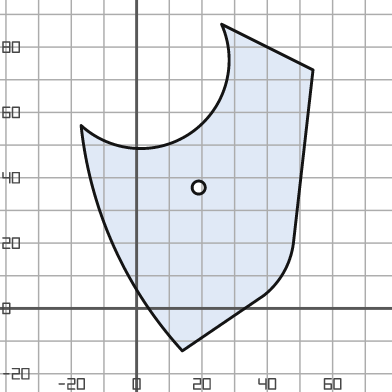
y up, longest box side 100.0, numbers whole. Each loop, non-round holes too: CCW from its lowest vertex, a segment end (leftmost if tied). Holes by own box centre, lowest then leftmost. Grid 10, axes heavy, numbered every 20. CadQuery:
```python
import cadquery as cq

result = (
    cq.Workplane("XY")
    .moveTo(14.0, -13.0)
    .lineTo(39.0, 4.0)
    .threePointArc((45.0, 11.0), (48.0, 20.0))
    .lineTo(54.0, 73.0)
    .lineTo(26.0, 87.0)
    .threePointArc((17.0, 54.0), (-17.0, 56.0))
    .threePointArc((-7.0, 19.0), (14.0, -13.0))
    .close()
    .moveTo(19.0, 37.0)
    .circle(2.0)
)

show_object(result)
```